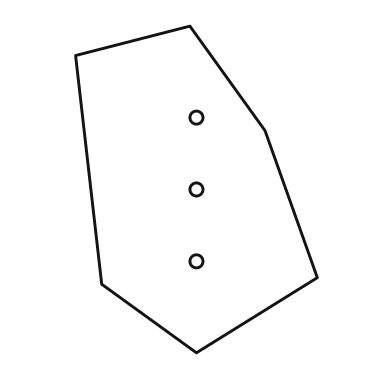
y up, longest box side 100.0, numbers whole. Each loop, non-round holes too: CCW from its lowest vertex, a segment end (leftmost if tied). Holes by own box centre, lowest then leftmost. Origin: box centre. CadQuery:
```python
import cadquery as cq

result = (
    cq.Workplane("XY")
    .moveTo(0.0, -50.0)
    .lineTo(37.0, -27.0)
    .lineTo(21.0, 18.0)
    .lineTo(-2.0, 50.0)
    .lineTo(-37.0, 41.0)
    .lineTo(-29.0, -29.0)
    .close()
    .moveTo(0.0, -22.0)
    .circle(2.0)
    .moveTo(0.0, 0.0)
    .circle(2.0)
    .moveTo(0.0, 22.0)
    .circle(2.0)
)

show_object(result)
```